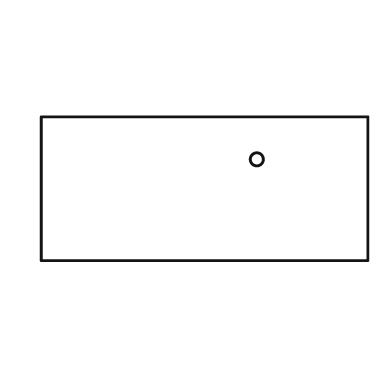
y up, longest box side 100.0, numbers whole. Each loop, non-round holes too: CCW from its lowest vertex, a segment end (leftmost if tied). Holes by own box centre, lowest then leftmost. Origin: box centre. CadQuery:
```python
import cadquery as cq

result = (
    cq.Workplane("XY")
    .moveTo(-50.0, -22.0)
    .lineTo(50.0, -22.0)
    .lineTo(50.0, 22.0)
    .lineTo(-50.0, 22.0)
    .close()
    .moveTo(16.0, 9.0)
    .circle(2.0)
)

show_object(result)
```